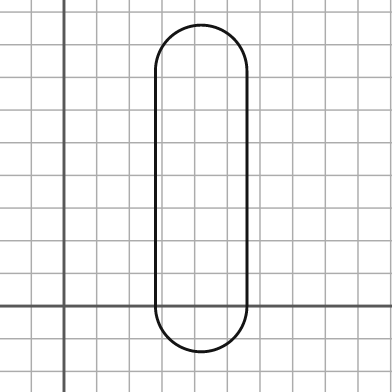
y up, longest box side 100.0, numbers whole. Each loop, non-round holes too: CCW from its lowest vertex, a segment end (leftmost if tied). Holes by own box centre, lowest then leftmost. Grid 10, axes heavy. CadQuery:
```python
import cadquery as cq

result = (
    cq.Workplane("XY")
    .moveTo(28.0, 0.0)
    .threePointArc((42.0, -14.0), (56.0, 0.0))
    .lineTo(56.0, 72.0)
    .threePointArc((42.0, 86.0), (28.0, 72.0))
    .close()
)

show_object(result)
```